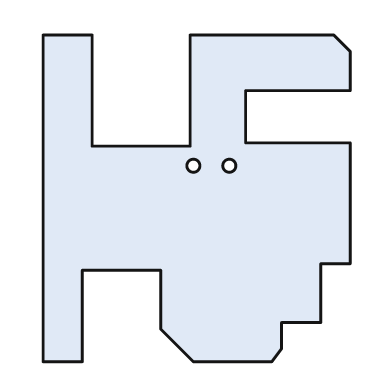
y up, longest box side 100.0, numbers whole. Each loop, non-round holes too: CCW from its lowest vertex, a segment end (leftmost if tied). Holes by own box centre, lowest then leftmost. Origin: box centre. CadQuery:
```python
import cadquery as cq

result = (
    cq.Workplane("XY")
    .moveTo(-47.0, -50.0)
    .lineTo(-35.0, -50.0)
    .lineTo(-35.0, -22.0)
    .lineTo(-11.0, -22.0)
    .lineTo(-11.0, -40.0)
    .lineTo(-1.0, -50.0)
    .lineTo(23.0, -50.0)
    .lineTo(26.0, -46.0)
    .lineTo(26.0, -38.0)
    .lineTo(38.0, -38.0)
    .lineTo(38.0, -20.0)
    .lineTo(47.0, -20.0)
    .lineTo(47.0, 17.0)
    .lineTo(15.0, 17.0)
    .lineTo(15.0, 33.0)
    .lineTo(47.0, 33.0)
    .lineTo(47.0, 45.0)
    .lineTo(42.0, 50.0)
    .lineTo(-2.0, 50.0)
    .lineTo(-2.0, 16.0)
    .lineTo(-32.0, 16.0)
    .lineTo(-32.0, 50.0)
    .lineTo(-47.0, 50.0)
    .close()
    .moveTo(-1.0, 10.0)
    .circle(2.0)
    .moveTo(10.0, 10.0)
    .circle(2.0)
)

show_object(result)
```